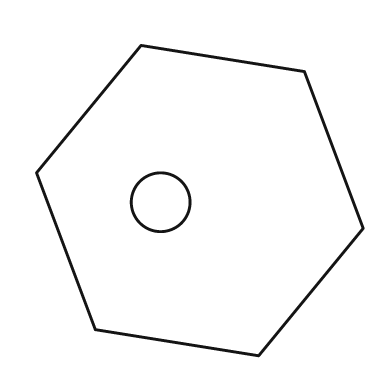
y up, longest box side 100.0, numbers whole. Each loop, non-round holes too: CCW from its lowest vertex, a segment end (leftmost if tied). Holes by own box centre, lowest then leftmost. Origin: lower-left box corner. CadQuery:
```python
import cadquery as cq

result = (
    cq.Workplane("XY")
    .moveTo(68.0, 0.0)
    .lineTo(100.0, 39.0)
    .lineTo(82.0, 87.0)
    .lineTo(32.0, 95.0)
    .lineTo(0.0, 56.0)
    .lineTo(18.0, 8.0)
    .close()
    .moveTo(38.0, 47.0)
    .circle(9.0)
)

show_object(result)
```